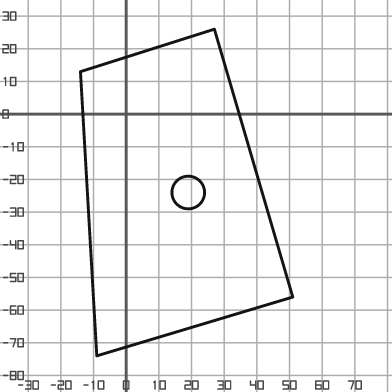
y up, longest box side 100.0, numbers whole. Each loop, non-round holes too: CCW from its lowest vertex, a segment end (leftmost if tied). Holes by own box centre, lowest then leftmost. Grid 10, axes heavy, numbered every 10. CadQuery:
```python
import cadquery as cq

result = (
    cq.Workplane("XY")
    .moveTo(-9.0, -74.0)
    .lineTo(51.0, -56.0)
    .lineTo(27.0, 26.0)
    .lineTo(-14.0, 13.0)
    .close()
    .moveTo(19.0, -24.0)
    .circle(5.0)
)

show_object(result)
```